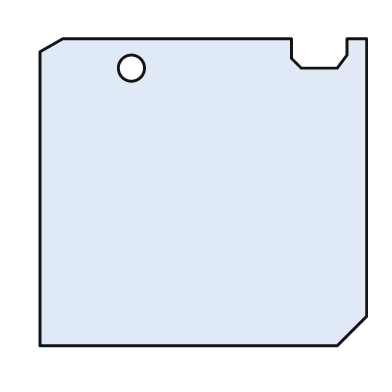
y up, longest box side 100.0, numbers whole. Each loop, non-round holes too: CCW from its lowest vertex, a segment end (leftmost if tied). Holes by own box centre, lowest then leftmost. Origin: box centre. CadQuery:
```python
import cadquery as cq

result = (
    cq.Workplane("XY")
    .moveTo(-50.0, -47.0)
    .lineTo(41.0, -47.0)
    .lineTo(50.0, -38.0)
    .lineTo(50.0, 47.0)
    .lineTo(44.0, 47.0)
    .lineTo(44.0, 42.0)
    .lineTo(41.0, 38.0)
    .lineTo(30.0, 38.0)
    .lineTo(27.0, 41.0)
    .lineTo(27.0, 47.0)
    .lineTo(-43.0, 47.0)
    .lineTo(-50.0, 43.0)
    .close()
    .moveTo(-22.0, 38.0)
    .circle(4.0)
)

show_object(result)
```